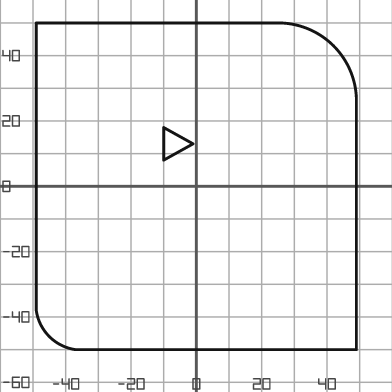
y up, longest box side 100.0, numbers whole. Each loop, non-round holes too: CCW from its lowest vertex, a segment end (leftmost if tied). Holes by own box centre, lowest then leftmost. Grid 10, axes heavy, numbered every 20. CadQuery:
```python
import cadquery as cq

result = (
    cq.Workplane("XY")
    .moveTo(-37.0, -50.0)
    .lineTo(49.0, -50.0)
    .lineTo(49.0, 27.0)
    .threePointArc((42.0, 43.0), (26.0, 50.0))
    .lineTo(-49.0, 50.0)
    .lineTo(-49.0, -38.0)
    .threePointArc((-45.0, -46.0), (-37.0, -50.0))
    .close()
    .moveTo(-10.0, 8.0)
    .lineTo(-1.0, 13.0)
    .lineTo(-10.0, 18.0)
    .close()
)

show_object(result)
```